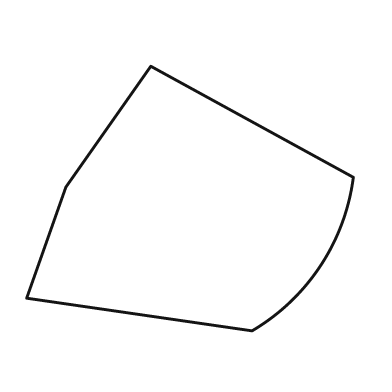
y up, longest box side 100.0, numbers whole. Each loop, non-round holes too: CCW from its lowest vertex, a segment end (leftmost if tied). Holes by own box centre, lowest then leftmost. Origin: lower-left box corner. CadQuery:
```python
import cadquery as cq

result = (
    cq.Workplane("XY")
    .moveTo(69.0, 0.0)
    .threePointArc((90.0, 20.0), (100.0, 47.0))
    .lineTo(38.0, 81.0)
    .lineTo(12.0, 44.0)
    .lineTo(0.0, 10.0)
    .close()
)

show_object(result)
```